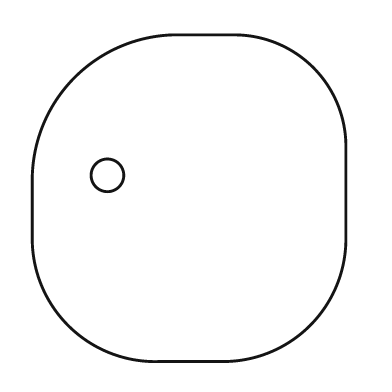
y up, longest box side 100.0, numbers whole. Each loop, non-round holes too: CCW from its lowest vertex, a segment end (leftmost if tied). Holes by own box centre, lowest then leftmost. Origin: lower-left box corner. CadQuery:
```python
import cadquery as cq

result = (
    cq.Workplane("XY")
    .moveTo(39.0, 0.0)
    .lineTo(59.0, 0.0)
    .threePointArc((85.0, 11.0), (96.0, 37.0))
    .lineTo(96.0, 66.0)
    .threePointArc((86.0, 90.0), (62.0, 100.0))
    .lineTo(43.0, 100.0)
    .threePointArc((13.0, 87.0), (0.0, 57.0))
    .lineTo(0.0, 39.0)
    .threePointArc((11.0, 11.0), (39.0, 0.0))
    .close()
    .moveTo(23.0, 57.0)
    .circle(5.0)
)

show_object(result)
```